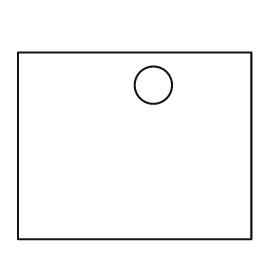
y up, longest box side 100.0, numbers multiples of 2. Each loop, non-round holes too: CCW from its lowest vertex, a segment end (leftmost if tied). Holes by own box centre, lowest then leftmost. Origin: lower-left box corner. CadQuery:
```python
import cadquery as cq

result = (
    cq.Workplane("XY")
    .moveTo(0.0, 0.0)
    .lineTo(100.0, 0.0)
    .lineTo(100.0, 80.0)
    .lineTo(0.0, 80.0)
    .close()
    .moveTo(58.0, 66.0)
    .circle(8.0)
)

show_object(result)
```